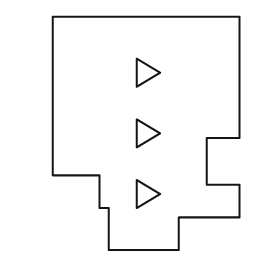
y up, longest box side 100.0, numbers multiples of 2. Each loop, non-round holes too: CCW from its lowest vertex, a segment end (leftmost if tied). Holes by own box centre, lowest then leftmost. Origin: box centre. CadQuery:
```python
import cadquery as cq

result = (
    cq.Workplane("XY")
    .moveTo(-16.0, -50.0)
    .lineTo(14.0, -50.0)
    .lineTo(14.0, -36.0)
    .lineTo(40.0, -36.0)
    .lineTo(40.0, -22.0)
    .lineTo(26.0, -22.0)
    .lineTo(26.0, -2.0)
    .lineTo(40.0, -2.0)
    .lineTo(40.0, 50.0)
    .lineTo(-40.0, 50.0)
    .lineTo(-40.0, -18.0)
    .lineTo(-20.0, -18.0)
    .lineTo(-20.0, -32.0)
    .lineTo(-16.0, -32.0)
    .close()
    .moveTo(-4.0, -32.0)
    .lineTo(6.0, -26.0)
    .lineTo(-4.0, -20.0)
    .close()
    .moveTo(-4.0, -6.0)
    .lineTo(6.0, 0.0)
    .lineTo(-4.0, 6.0)
    .close()
    .moveTo(-4.0, 20.0)
    .lineTo(6.0, 26.0)
    .lineTo(-4.0, 32.0)
    .close()
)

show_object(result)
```